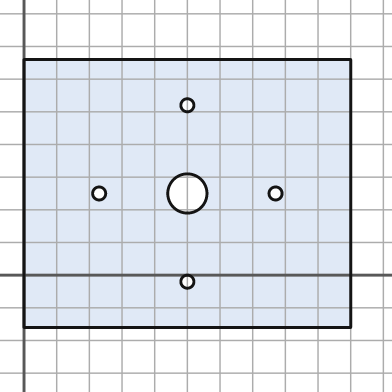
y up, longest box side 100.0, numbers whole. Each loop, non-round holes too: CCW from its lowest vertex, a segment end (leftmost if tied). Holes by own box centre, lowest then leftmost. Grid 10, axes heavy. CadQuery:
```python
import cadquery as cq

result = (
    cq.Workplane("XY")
    .moveTo(0.0, -16.0)
    .lineTo(100.0, -16.0)
    .lineTo(100.0, 66.0)
    .lineTo(0.0, 66.0)
    .close()
    .moveTo(50.0, -2.0)
    .circle(2.0)
    .moveTo(23.0, 25.0)
    .circle(2.0)
    .moveTo(50.0, 25.0)
    .circle(6.0)
    .moveTo(77.0, 25.0)
    .circle(2.0)
    .moveTo(50.0, 52.0)
    .circle(2.0)
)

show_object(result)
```